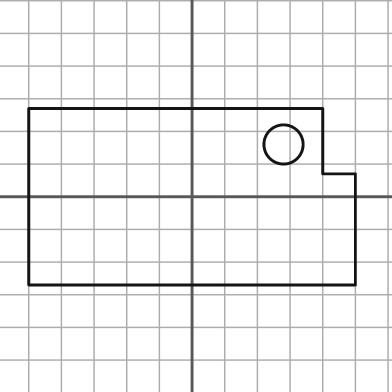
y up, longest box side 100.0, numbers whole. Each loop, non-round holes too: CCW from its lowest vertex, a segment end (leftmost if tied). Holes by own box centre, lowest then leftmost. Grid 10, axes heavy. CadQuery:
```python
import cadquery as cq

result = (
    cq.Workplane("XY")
    .moveTo(-50.0, -27.0)
    .lineTo(50.0, -27.0)
    .lineTo(50.0, 7.0)
    .lineTo(40.0, 7.0)
    .lineTo(40.0, 27.0)
    .lineTo(-50.0, 27.0)
    .close()
    .moveTo(28.0, 16.0)
    .circle(6.0)
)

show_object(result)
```